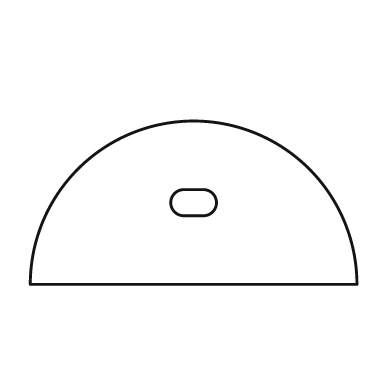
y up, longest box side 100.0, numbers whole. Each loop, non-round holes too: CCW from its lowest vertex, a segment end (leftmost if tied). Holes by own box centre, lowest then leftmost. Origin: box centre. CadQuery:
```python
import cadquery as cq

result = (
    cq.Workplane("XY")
    .moveTo(-50.0, -25.0)
    .lineTo(50.0, -25.0)
    .threePointArc((0.0, 25.0), (-50.0, -25.0))
    .close()
    .moveTo(-3.0, -4.0)
    .lineTo(3.0, -4.0)
    .threePointArc((7.0, 0.0), (3.0, 4.0))
    .lineTo(-3.0, 4.0)
    .threePointArc((-7.0, 0.0), (-3.0, -4.0))
    .close()
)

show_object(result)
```